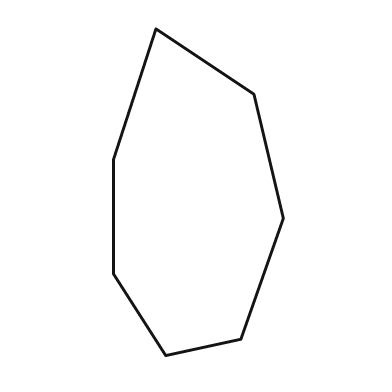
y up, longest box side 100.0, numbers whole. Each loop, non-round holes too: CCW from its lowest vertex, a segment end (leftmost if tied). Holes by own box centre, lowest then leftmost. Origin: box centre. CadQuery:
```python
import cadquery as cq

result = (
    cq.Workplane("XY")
    .moveTo(-10.0, -50.0)
    .lineTo(13.0, -45.0)
    .lineTo(26.0, -8.0)
    .lineTo(17.0, 30.0)
    .lineTo(-13.0, 50.0)
    .lineTo(-26.0, 10.0)
    .lineTo(-26.0, -25.0)
    .close()
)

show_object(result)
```